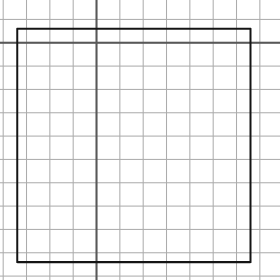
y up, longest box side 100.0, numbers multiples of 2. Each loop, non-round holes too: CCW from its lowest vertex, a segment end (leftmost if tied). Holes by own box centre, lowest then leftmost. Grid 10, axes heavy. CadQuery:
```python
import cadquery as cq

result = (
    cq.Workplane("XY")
    .moveTo(-34.0, -94.0)
    .lineTo(66.0, -94.0)
    .lineTo(66.0, 6.0)
    .lineTo(-34.0, 6.0)
    .close()
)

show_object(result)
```